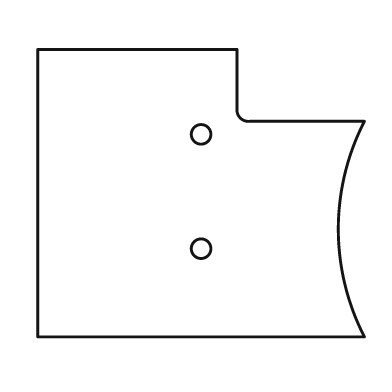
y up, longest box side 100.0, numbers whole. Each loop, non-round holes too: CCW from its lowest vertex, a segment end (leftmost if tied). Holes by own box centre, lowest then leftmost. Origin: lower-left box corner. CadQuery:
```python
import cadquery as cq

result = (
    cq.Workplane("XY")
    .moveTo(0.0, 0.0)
    .lineTo(100.0, 0.0)
    .threePointArc((92.0, 33.0), (100.0, 66.0))
    .lineTo(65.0, 66.0)
    .threePointArc((62.0, 67.0), (61.0, 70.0))
    .lineTo(61.0, 88.0)
    .lineTo(0.0, 88.0)
    .close()
    .moveTo(50.0, 27.0)
    .circle(3.0)
    .moveTo(50.0, 62.0)
    .circle(3.0)
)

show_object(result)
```